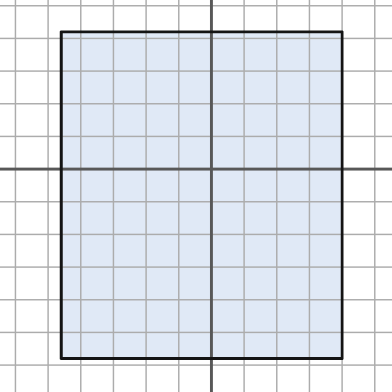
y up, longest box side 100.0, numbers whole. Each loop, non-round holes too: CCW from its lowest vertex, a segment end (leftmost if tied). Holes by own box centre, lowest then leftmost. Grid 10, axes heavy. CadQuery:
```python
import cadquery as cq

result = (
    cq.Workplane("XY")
    .moveTo(-46.0, -58.0)
    .lineTo(40.0, -58.0)
    .lineTo(40.0, 42.0)
    .lineTo(-46.0, 42.0)
    .close()
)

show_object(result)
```